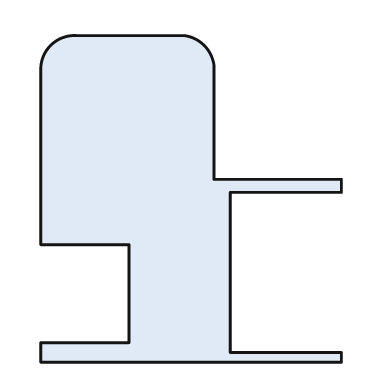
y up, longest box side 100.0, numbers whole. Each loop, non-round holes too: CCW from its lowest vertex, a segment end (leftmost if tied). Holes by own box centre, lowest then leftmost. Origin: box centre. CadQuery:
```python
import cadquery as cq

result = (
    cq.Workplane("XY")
    .moveTo(-46.0, -50.0)
    .lineTo(46.0, -50.0)
    .lineTo(46.0, -47.0)
    .lineTo(12.0, -47.0)
    .lineTo(12.0, 2.0)
    .lineTo(46.0, 2.0)
    .lineTo(46.0, 6.0)
    .lineTo(7.0, 6.0)
    .lineTo(7.0, 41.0)
    .threePointArc((4.0, 47.0), (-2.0, 50.0))
    .lineTo(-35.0, 50.0)
    .threePointArc((-43.0, 47.0), (-46.0, 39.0))
    .lineTo(-46.0, -14.0)
    .lineTo(-19.0, -14.0)
    .lineTo(-19.0, -44.0)
    .lineTo(-46.0, -44.0)
    .close()
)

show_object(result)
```